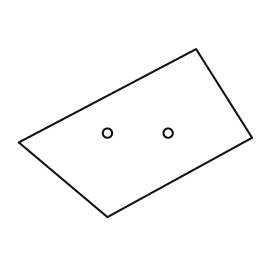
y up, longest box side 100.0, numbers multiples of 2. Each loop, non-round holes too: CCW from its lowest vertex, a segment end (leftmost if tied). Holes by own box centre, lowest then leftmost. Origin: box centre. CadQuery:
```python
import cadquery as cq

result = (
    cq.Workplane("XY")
    .moveTo(-12.0, -36.0)
    .lineTo(50.0, -2.0)
    .lineTo(26.0, 36.0)
    .lineTo(-50.0, -4.0)
    .close()
    .moveTo(-12.0, 0.0)
    .circle(2.0)
    .moveTo(14.0, 0.0)
    .circle(2.0)
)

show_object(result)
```